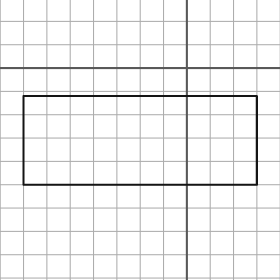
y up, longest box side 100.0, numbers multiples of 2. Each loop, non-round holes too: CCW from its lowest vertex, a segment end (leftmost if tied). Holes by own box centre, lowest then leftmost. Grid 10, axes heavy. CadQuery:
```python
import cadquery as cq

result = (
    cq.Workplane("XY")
    .moveTo(-70.0, -50.0)
    .lineTo(30.0, -50.0)
    .lineTo(30.0, -12.0)
    .lineTo(-70.0, -12.0)
    .close()
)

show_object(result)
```